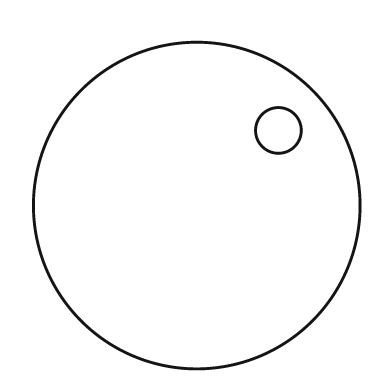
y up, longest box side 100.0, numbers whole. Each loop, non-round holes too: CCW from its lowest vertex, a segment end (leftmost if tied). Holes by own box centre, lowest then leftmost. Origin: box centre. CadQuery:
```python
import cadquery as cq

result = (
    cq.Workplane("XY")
    .moveTo(0.0, 0.0)
    .circle(50.0)
    .moveTo(25.0, 23.0)
    .circle(7.0)
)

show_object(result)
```